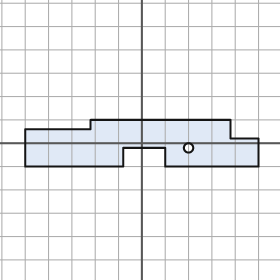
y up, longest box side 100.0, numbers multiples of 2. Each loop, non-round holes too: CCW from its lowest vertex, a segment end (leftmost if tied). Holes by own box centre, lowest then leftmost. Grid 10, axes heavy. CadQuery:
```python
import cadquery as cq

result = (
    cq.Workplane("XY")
    .moveTo(-50.0, -10.0)
    .lineTo(-8.0, -10.0)
    .lineTo(-8.0, -2.0)
    .lineTo(10.0, -2.0)
    .lineTo(10.0, -10.0)
    .lineTo(50.0, -10.0)
    .lineTo(50.0, 2.0)
    .lineTo(38.0, 2.0)
    .lineTo(38.0, 10.0)
    .lineTo(-22.0, 10.0)
    .lineTo(-22.0, 6.0)
    .lineTo(-50.0, 6.0)
    .close()
    .moveTo(20.0, -2.0)
    .circle(2.0)
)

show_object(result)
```